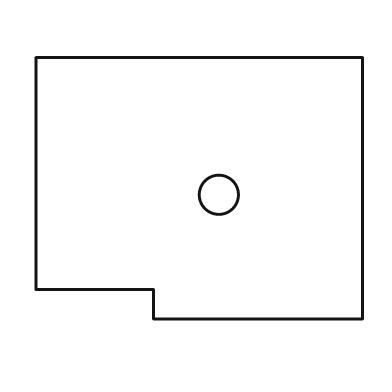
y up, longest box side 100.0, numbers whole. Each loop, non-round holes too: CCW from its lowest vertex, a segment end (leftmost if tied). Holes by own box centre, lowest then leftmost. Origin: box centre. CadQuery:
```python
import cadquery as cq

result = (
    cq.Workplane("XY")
    .moveTo(-14.0, -40.0)
    .lineTo(50.0, -40.0)
    .lineTo(50.0, 40.0)
    .lineTo(-50.0, 40.0)
    .lineTo(-50.0, -31.0)
    .lineTo(-14.0, -31.0)
    .close()
    .moveTo(6.0, -2.0)
    .circle(6.0)
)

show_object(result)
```